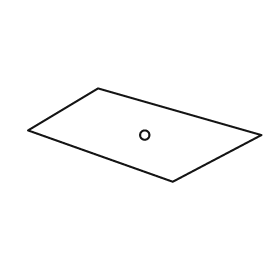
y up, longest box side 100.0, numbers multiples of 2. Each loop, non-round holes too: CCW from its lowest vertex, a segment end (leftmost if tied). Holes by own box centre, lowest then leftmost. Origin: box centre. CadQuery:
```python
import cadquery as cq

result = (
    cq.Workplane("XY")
    .moveTo(12.0, -20.0)
    .lineTo(50.0, 0.0)
    .lineTo(-20.0, 20.0)
    .lineTo(-50.0, 2.0)
    .close()
    .moveTo(0.0, 0.0)
    .circle(2.0)
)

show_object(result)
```